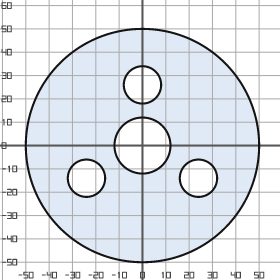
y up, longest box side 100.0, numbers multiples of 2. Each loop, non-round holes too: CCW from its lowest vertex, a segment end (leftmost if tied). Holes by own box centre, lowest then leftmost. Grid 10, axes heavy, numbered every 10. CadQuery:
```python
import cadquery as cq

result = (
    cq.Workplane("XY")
    .moveTo(0.0, 0.0)
    .circle(50.0)
    .moveTo(-24.0, -14.0)
    .circle(8.0)
    .moveTo(24.0, -14.0)
    .circle(8.0)
    .moveTo(0.0, 0.0)
    .circle(12.0)
    .moveTo(0.0, 26.0)
    .circle(8.0)
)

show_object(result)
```